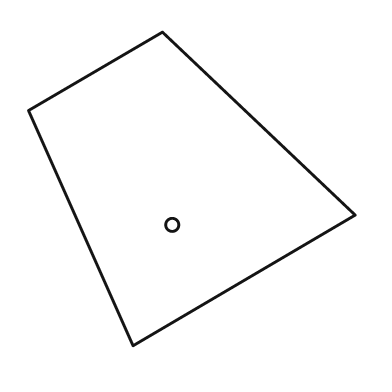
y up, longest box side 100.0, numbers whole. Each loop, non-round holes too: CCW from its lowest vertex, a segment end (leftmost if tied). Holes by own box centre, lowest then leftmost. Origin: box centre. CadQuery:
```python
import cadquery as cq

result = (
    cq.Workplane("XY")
    .moveTo(-18.0, -48.0)
    .lineTo(50.0, -8.0)
    .lineTo(-9.0, 48.0)
    .lineTo(-50.0, 24.0)
    .close()
    .moveTo(-6.0, -11.0)
    .circle(2.0)
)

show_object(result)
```